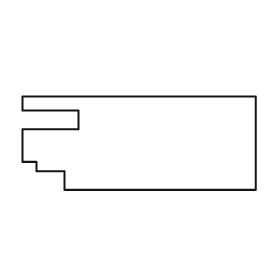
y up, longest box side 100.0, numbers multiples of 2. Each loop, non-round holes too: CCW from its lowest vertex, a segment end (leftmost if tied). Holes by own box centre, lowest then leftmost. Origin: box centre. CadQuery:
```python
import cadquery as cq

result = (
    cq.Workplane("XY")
    .moveTo(-32.0, -20.0)
    .lineTo(50.0, -20.0)
    .lineTo(50.0, 20.0)
    .lineTo(-50.0, 20.0)
    .lineTo(-50.0, 14.0)
    .lineTo(-26.0, 14.0)
    .lineTo(-26.0, 6.0)
    .lineTo(-50.0, 6.0)
    .lineTo(-50.0, -8.0)
    .lineTo(-44.0, -8.0)
    .lineTo(-44.0, -12.0)
    .lineTo(-32.0, -12.0)
    .close()
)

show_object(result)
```